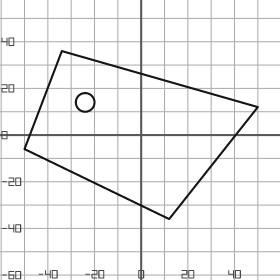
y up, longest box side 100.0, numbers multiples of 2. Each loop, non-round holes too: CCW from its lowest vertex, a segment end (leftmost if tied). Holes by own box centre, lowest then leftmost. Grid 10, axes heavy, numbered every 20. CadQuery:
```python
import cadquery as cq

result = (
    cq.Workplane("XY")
    .moveTo(12.0, -36.0)
    .lineTo(50.0, 12.0)
    .lineTo(-34.0, 36.0)
    .lineTo(-50.0, -6.0)
    .close()
    .moveTo(-24.0, 14.0)
    .circle(4.0)
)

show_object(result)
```